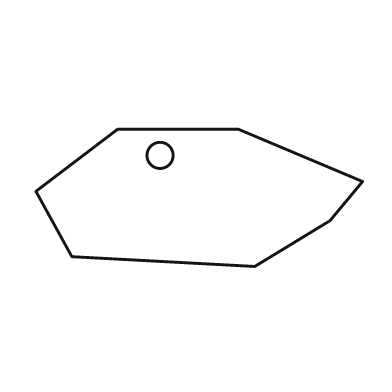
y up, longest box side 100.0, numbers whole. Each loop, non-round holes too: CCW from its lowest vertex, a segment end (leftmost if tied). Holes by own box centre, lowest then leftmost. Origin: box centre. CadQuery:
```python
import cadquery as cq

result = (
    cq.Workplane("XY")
    .moveTo(17.0, -21.0)
    .lineTo(40.0, -7.0)
    .lineTo(50.0, 5.0)
    .lineTo(12.0, 21.0)
    .lineTo(-25.0, 21.0)
    .lineTo(-50.0, 2.0)
    .lineTo(-39.0, -18.0)
    .close()
    .moveTo(-12.0, 13.0)
    .circle(4.0)
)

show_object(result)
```